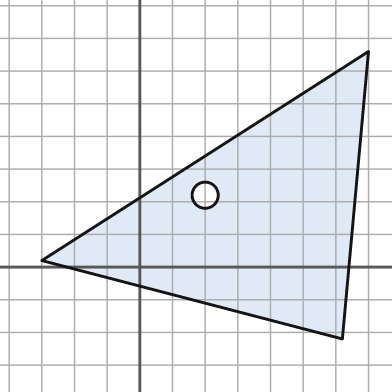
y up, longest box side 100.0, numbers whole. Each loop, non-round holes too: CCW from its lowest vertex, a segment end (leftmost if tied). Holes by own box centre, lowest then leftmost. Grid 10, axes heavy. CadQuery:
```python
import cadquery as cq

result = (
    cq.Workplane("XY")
    .moveTo(62.0, -22.0)
    .lineTo(70.0, 66.0)
    .lineTo(-30.0, 2.0)
    .close()
    .moveTo(20.0, 22.0)
    .circle(4.0)
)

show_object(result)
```